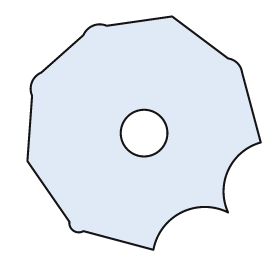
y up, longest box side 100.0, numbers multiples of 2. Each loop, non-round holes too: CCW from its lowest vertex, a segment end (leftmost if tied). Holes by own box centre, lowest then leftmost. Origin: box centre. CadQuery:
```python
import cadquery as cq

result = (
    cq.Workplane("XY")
    .moveTo(4.0, -50.0)
    .threePointArc((16.0, -34.0), (36.0, -34.0))
    .threePointArc((36.0, -16.0), (50.0, -4.0))
    .lineTo(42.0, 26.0)
    .threePointArc((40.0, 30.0), (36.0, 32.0))
    .lineTo(12.0, 50.0)
    .lineTo(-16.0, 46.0)
    .threePointArc((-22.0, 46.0), (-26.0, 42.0))
    .lineTo(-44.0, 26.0)
    .threePointArc((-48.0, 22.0), (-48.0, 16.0))
    .lineTo(-50.0, -12.0)
    .lineTo(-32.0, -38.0)
    .threePointArc((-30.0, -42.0), (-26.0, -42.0))
    .close()
    .moveTo(0.0, 0.0)
    .circle(10.0)
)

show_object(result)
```